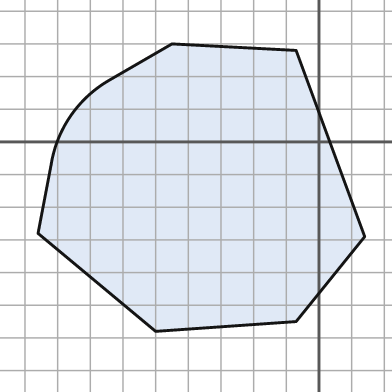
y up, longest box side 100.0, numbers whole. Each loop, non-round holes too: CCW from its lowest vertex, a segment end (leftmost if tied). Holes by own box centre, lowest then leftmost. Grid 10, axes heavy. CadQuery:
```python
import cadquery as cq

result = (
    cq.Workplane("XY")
    .moveTo(-50.0, -58.0)
    .lineTo(-7.0, -55.0)
    .lineTo(14.0, -29.0)
    .lineTo(-7.0, 28.0)
    .lineTo(-45.0, 30.0)
    .lineTo(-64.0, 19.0)
    .threePointArc((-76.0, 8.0), (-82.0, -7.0))
    .lineTo(-86.0, -28.0)
    .close()
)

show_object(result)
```